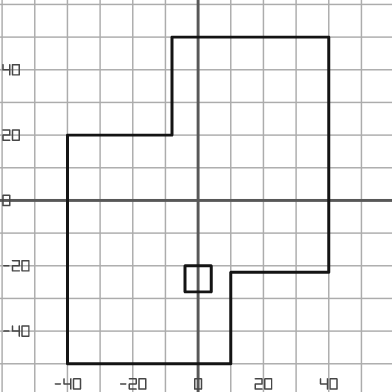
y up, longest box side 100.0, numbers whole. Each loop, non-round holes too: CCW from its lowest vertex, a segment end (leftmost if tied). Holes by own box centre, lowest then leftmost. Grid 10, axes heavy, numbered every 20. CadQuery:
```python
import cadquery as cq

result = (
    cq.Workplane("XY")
    .moveTo(-40.0, -50.0)
    .lineTo(10.0, -50.0)
    .lineTo(10.0, -22.0)
    .lineTo(40.0, -22.0)
    .lineTo(40.0, 50.0)
    .lineTo(-8.0, 50.0)
    .lineTo(-8.0, 20.0)
    .lineTo(-40.0, 20.0)
    .close()
    .moveTo(-4.0, -28.0)
    .lineTo(4.0, -28.0)
    .lineTo(4.0, -20.0)
    .lineTo(-4.0, -20.0)
    .close()
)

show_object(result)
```